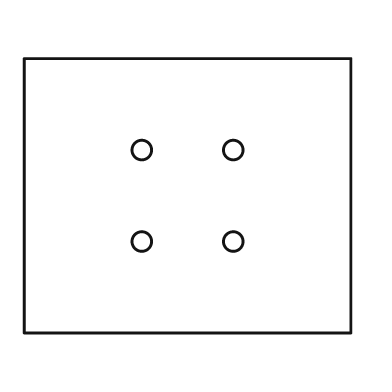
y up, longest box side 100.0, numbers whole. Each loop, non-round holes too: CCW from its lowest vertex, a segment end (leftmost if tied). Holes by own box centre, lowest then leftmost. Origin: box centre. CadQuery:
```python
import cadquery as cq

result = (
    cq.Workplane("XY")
    .moveTo(-50.0, -42.0)
    .lineTo(50.0, -42.0)
    .lineTo(50.0, 42.0)
    .lineTo(-50.0, 42.0)
    .close()
    .moveTo(-14.0, -14.0)
    .circle(3.0)
    .moveTo(14.0, -14.0)
    .circle(3.0)
    .moveTo(-14.0, 14.0)
    .circle(3.0)
    .moveTo(14.0, 14.0)
    .circle(3.0)
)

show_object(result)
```